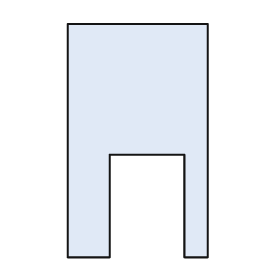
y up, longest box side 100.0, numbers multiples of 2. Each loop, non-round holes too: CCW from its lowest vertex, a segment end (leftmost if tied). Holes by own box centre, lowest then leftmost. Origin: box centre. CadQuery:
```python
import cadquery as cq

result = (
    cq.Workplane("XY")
    .moveTo(-30.0, -50.0)
    .lineTo(-12.0, -50.0)
    .lineTo(-12.0, -6.0)
    .lineTo(20.0, -6.0)
    .lineTo(20.0, -50.0)
    .lineTo(30.0, -50.0)
    .lineTo(30.0, 50.0)
    .lineTo(-30.0, 50.0)
    .close()
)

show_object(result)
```